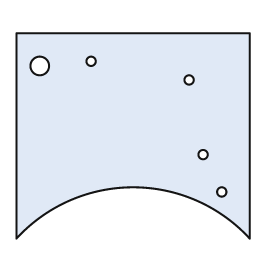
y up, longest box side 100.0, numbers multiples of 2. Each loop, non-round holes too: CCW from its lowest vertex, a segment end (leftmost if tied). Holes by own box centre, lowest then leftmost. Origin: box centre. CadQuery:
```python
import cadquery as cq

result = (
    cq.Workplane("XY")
    .moveTo(-50.0, -44.0)
    .threePointArc((0.0, -22.0), (50.0, -44.0))
    .lineTo(50.0, 44.0)
    .lineTo(-50.0, 44.0)
    .close()
    .moveTo(38.0, -24.0)
    .circle(2.0)
    .moveTo(30.0, -8.0)
    .circle(2.0)
    .moveTo(24.0, 24.0)
    .circle(2.0)
    .moveTo(-40.0, 30.0)
    .circle(4.0)
    .moveTo(-18.0, 32.0)
    .circle(2.0)
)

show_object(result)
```